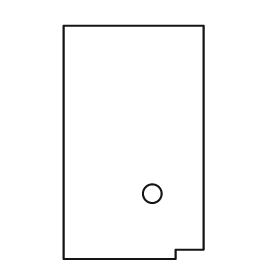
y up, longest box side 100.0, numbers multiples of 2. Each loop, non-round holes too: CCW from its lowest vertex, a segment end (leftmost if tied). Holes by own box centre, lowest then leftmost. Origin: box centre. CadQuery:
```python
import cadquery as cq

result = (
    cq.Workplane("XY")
    .moveTo(-30.0, -50.0)
    .lineTo(18.0, -50.0)
    .lineTo(18.0, -46.0)
    .lineTo(30.0, -46.0)
    .lineTo(30.0, 50.0)
    .lineTo(-30.0, 50.0)
    .close()
    .moveTo(8.0, -22.0)
    .circle(4.0)
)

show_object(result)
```